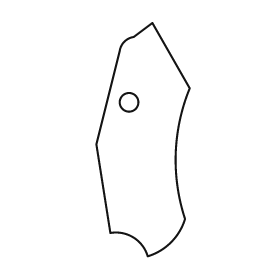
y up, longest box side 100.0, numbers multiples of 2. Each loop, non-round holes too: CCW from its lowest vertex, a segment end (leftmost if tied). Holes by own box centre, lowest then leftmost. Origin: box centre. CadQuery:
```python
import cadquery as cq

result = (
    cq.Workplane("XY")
    .moveTo(2.0, -50.0)
    .threePointArc((12.0, -44.0), (18.0, -34.0))
    .threePointArc((14.0, -6.0), (20.0, 22.0))
    .lineTo(4.0, 50.0)
    .lineTo(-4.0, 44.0)
    .threePointArc((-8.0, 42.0), (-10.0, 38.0))
    .lineTo(-20.0, -2.0)
    .lineTo(-14.0, -40.0)
    .threePointArc((-4.0, -42.0), (2.0, -50.0))
    .close()
    .moveTo(-6.0, 16.0)
    .circle(4.0)
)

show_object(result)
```